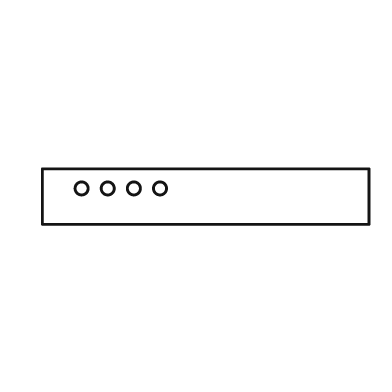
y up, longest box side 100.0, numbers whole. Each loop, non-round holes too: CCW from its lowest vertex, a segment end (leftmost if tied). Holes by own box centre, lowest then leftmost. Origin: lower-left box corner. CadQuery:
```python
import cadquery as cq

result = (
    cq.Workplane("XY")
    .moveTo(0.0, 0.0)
    .lineTo(100.0, 0.0)
    .lineTo(100.0, 17.0)
    .lineTo(0.0, 17.0)
    .close()
    .moveTo(12.0, 11.0)
    .circle(2.0)
    .moveTo(20.0, 11.0)
    .circle(2.0)
    .moveTo(28.0, 11.0)
    .circle(2.0)
    .moveTo(36.0, 11.0)
    .circle(2.0)
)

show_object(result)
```